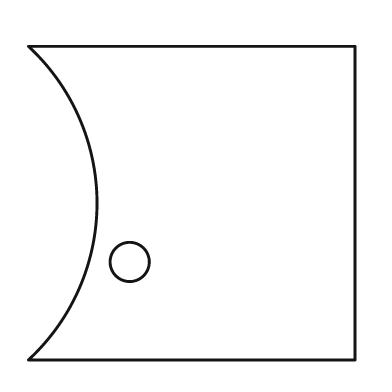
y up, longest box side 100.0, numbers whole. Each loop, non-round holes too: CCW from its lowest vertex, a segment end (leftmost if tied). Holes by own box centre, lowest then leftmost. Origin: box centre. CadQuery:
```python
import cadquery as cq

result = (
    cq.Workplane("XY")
    .moveTo(-50.0, -48.0)
    .lineTo(50.0, -48.0)
    .lineTo(50.0, 48.0)
    .lineTo(-50.0, 48.0)
    .threePointArc((-29.0, 0.0), (-50.0, -48.0))
    .close()
    .moveTo(-19.0, -18.0)
    .circle(6.0)
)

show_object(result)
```